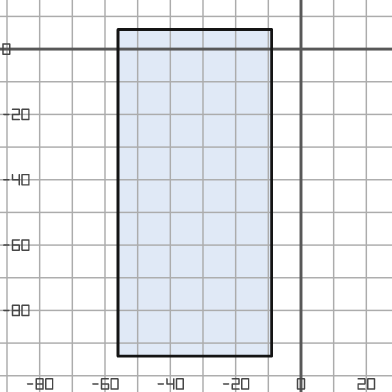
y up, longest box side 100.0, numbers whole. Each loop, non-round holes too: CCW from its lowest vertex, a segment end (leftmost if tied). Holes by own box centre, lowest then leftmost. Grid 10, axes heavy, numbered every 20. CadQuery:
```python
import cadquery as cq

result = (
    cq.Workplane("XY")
    .moveTo(-56.0, -94.0)
    .lineTo(-9.0, -94.0)
    .lineTo(-9.0, 6.0)
    .lineTo(-56.0, 6.0)
    .close()
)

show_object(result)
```